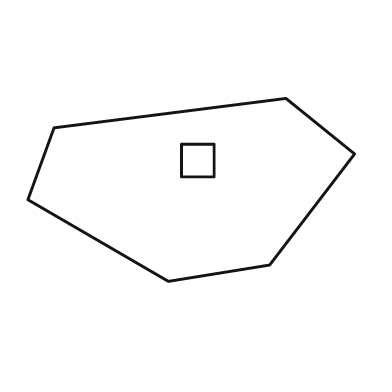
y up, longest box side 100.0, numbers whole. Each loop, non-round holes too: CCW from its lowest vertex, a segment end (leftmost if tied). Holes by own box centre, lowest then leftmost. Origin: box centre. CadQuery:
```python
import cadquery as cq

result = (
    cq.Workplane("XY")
    .moveTo(-7.0, -28.0)
    .lineTo(24.0, -23.0)
    .lineTo(50.0, 11.0)
    .lineTo(29.0, 28.0)
    .lineTo(-42.0, 19.0)
    .lineTo(-50.0, -3.0)
    .close()
    .moveTo(-3.0, 4.0)
    .lineTo(7.0, 4.0)
    .lineTo(7.0, 14.0)
    .lineTo(-3.0, 14.0)
    .close()
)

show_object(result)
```